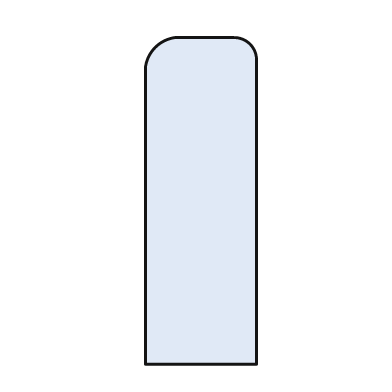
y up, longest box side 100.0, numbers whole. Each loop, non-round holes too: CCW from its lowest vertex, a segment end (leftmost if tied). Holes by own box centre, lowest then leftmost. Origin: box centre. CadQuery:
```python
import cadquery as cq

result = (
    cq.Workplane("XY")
    .moveTo(-17.0, -50.0)
    .lineTo(17.0, -50.0)
    .lineTo(17.0, 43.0)
    .threePointArc((15.0, 48.0), (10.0, 50.0))
    .lineTo(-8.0, 50.0)
    .threePointArc((-14.0, 47.0), (-17.0, 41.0))
    .close()
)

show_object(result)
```